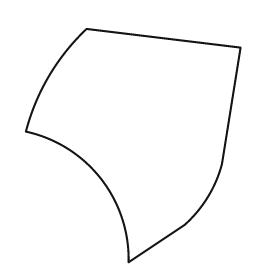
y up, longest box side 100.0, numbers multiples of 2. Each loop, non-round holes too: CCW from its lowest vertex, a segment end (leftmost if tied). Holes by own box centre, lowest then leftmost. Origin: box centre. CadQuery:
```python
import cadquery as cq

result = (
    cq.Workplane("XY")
    .moveTo(-2.0, -50.0)
    .lineTo(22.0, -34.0)
    .threePointArc((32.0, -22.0), (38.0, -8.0))
    .lineTo(46.0, 42.0)
    .lineTo(-20.0, 50.0)
    .threePointArc((-36.0, 30.0), (-46.0, 6.0))
    .threePointArc((-14.0, -14.0), (-2.0, -50.0))
    .close()
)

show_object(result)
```